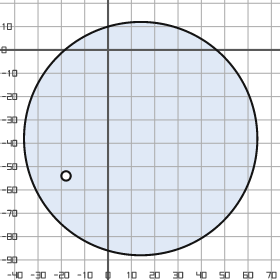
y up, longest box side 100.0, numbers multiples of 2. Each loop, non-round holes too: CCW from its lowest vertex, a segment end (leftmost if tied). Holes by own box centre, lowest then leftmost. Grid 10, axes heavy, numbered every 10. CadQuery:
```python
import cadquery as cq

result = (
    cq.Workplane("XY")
    .moveTo(14.0, -38.0)
    .circle(50.0)
    .moveTo(-18.0, -54.0)
    .circle(2.0)
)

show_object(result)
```